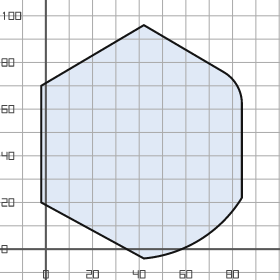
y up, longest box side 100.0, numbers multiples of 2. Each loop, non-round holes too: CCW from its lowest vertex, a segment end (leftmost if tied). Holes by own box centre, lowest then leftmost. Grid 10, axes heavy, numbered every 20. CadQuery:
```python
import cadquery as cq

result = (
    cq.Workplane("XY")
    .moveTo(42.0, -4.0)
    .threePointArc((66.0, 4.0), (84.0, 22.0))
    .lineTo(84.0, 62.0)
    .threePointArc((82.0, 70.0), (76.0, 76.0))
    .lineTo(42.0, 96.0)
    .lineTo(-2.0, 70.0)
    .lineTo(-2.0, 20.0)
    .close()
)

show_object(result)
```